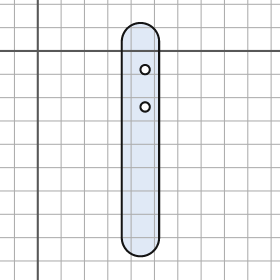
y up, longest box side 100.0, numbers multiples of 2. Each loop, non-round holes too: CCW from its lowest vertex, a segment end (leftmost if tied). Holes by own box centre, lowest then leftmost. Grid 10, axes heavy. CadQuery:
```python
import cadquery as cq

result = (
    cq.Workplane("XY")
    .moveTo(36.0, -80.0)
    .threePointArc((44.0, -88.0), (52.0, -80.0))
    .lineTo(52.0, 4.0)
    .threePointArc((44.0, 12.0), (36.0, 4.0))
    .close()
    .moveTo(46.0, -24.0)
    .circle(2.0)
    .moveTo(46.0, -8.0)
    .circle(2.0)
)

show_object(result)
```